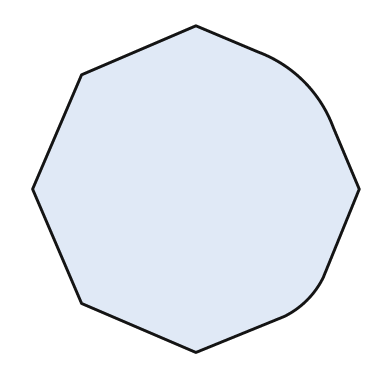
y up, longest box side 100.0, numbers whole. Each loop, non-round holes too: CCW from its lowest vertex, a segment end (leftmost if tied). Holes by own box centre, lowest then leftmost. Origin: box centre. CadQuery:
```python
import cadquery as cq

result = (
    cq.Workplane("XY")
    .moveTo(0.0, -50.0)
    .lineTo(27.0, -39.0)
    .threePointArc((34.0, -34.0), (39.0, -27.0))
    .lineTo(50.0, 0.0)
    .lineTo(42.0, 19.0)
    .threePointArc((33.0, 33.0), (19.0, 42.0))
    .lineTo(0.0, 50.0)
    .lineTo(-35.0, 35.0)
    .lineTo(-50.0, 0.0)
    .lineTo(-35.0, -35.0)
    .close()
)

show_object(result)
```